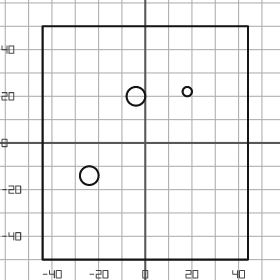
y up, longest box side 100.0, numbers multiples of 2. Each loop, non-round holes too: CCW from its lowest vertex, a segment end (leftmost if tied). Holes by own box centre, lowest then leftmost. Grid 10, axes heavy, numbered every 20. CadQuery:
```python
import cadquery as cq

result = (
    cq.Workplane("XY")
    .moveTo(-44.0, -50.0)
    .lineTo(44.0, -50.0)
    .lineTo(44.0, 50.0)
    .lineTo(-44.0, 50.0)
    .close()
    .moveTo(-24.0, -14.0)
    .circle(4.0)
    .moveTo(-4.0, 20.0)
    .circle(4.0)
    .moveTo(18.0, 22.0)
    .circle(2.0)
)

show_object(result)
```